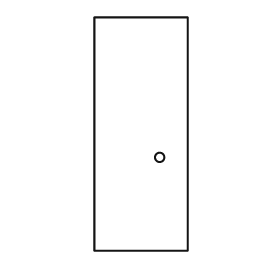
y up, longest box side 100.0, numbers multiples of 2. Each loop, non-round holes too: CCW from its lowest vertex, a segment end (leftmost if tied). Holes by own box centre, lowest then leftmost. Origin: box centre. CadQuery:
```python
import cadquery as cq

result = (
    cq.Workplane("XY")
    .moveTo(-20.0, -50.0)
    .lineTo(20.0, -50.0)
    .lineTo(20.0, 50.0)
    .lineTo(-20.0, 50.0)
    .close()
    .moveTo(8.0, -10.0)
    .circle(2.0)
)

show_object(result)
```